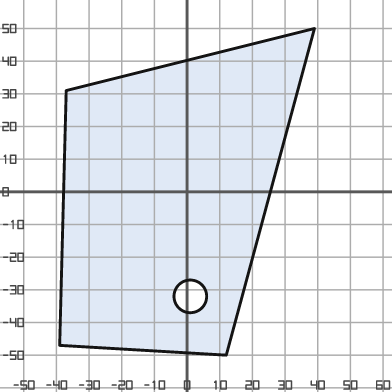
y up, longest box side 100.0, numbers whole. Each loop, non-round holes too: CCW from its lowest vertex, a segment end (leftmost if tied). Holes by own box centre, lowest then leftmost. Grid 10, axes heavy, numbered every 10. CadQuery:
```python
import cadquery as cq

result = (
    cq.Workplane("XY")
    .moveTo(12.0, -50.0)
    .lineTo(39.0, 50.0)
    .lineTo(-37.0, 31.0)
    .lineTo(-39.0, -47.0)
    .close()
    .moveTo(1.0, -32.0)
    .circle(5.0)
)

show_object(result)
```